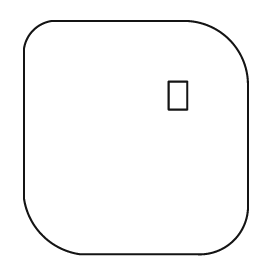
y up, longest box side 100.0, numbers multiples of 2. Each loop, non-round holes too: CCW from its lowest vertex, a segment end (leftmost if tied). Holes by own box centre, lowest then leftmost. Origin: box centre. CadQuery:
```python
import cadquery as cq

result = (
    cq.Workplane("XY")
    .moveTo(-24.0, -50.0)
    .lineTo(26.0, -50.0)
    .threePointArc((42.0, -44.0), (48.0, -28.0))
    .lineTo(48.0, 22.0)
    .threePointArc((40.0, 42.0), (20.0, 50.0))
    .lineTo(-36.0, 50.0)
    .threePointArc((-44.0, 46.0), (-48.0, 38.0))
    .lineTo(-48.0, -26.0)
    .threePointArc((-40.0, -42.0), (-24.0, -50.0))
    .close()
    .moveTo(14.0, 12.0)
    .lineTo(22.0, 12.0)
    .lineTo(22.0, 24.0)
    .lineTo(14.0, 24.0)
    .close()
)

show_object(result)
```